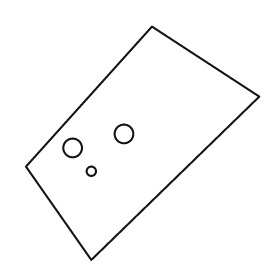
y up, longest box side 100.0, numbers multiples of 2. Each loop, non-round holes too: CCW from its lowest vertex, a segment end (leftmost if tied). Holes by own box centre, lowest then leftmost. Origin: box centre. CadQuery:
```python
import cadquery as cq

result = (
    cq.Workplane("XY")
    .moveTo(-22.0, -50.0)
    .lineTo(50.0, 20.0)
    .lineTo(4.0, 50.0)
    .lineTo(-50.0, -10.0)
    .close()
    .moveTo(-22.0, -12.0)
    .circle(2.0)
    .moveTo(-30.0, -2.0)
    .circle(4.0)
    .moveTo(-8.0, 4.0)
    .circle(4.0)
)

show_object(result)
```